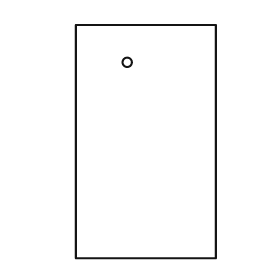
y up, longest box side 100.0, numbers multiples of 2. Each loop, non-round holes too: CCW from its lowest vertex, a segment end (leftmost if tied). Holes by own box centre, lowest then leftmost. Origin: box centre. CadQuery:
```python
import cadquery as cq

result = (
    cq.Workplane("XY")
    .moveTo(-30.0, -50.0)
    .lineTo(30.0, -50.0)
    .lineTo(30.0, 50.0)
    .lineTo(-30.0, 50.0)
    .close()
    .moveTo(-8.0, 34.0)
    .circle(2.0)
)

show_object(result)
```